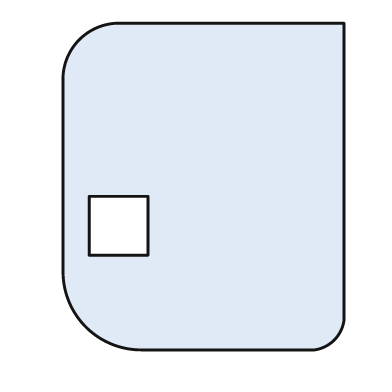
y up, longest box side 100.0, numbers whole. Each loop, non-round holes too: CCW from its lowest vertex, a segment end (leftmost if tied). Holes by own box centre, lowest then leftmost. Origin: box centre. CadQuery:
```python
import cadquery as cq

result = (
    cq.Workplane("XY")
    .moveTo(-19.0, -50.0)
    .lineTo(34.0, -50.0)
    .threePointArc((40.0, -47.0), (43.0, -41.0))
    .lineTo(43.0, 50.0)
    .lineTo(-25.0, 50.0)
    .threePointArc((-38.0, 45.0), (-43.0, 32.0))
    .lineTo(-43.0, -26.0)
    .threePointArc((-36.0, -43.0), (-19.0, -50.0))
    .close()
    .moveTo(-35.0, -21.0)
    .lineTo(-17.0, -21.0)
    .lineTo(-17.0, -3.0)
    .lineTo(-35.0, -3.0)
    .close()
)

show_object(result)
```